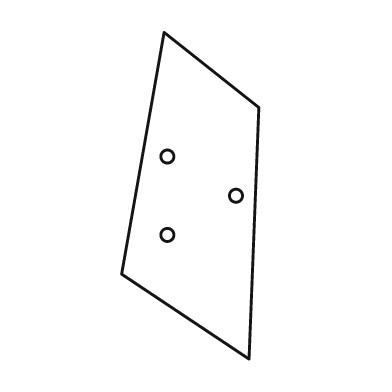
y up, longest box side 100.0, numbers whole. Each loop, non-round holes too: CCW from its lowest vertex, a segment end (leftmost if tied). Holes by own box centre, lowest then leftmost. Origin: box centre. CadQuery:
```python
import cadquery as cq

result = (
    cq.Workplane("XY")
    .moveTo(18.0, -50.0)
    .lineTo(21.0, 27.0)
    .lineTo(-8.0, 50.0)
    .lineTo(-21.0, -24.0)
    .close()
    .moveTo(-7.0, -12.0)
    .circle(2.0)
    .moveTo(14.0, 0.0)
    .circle(2.0)
    .moveTo(-7.0, 12.0)
    .circle(2.0)
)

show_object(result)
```